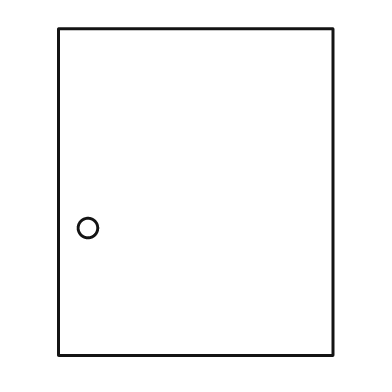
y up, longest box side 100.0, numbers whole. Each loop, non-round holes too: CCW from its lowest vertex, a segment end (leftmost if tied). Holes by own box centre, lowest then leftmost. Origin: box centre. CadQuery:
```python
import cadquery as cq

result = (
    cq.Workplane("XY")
    .moveTo(-42.0, -50.0)
    .lineTo(42.0, -50.0)
    .lineTo(42.0, 50.0)
    .lineTo(-42.0, 50.0)
    .close()
    .moveTo(-33.0, -11.0)
    .circle(3.0)
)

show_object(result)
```